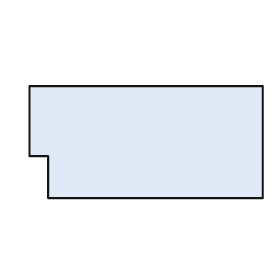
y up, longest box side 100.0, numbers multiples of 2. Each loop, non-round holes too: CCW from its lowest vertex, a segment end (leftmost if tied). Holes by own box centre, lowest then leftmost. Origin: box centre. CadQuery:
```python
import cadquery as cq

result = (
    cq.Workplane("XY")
    .moveTo(-42.0, -24.0)
    .lineTo(50.0, -24.0)
    .lineTo(50.0, 24.0)
    .lineTo(-50.0, 24.0)
    .lineTo(-50.0, -6.0)
    .lineTo(-42.0, -6.0)
    .close()
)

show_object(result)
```